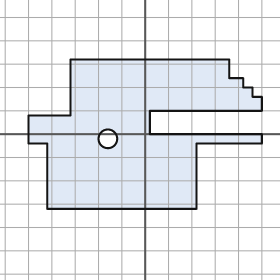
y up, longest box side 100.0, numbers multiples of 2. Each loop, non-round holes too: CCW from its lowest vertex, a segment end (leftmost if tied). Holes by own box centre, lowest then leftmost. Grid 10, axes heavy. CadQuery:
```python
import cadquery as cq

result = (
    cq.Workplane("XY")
    .moveTo(-42.0, -32.0)
    .lineTo(22.0, -32.0)
    .lineTo(22.0, -4.0)
    .lineTo(50.0, -4.0)
    .lineTo(50.0, 0.0)
    .lineTo(2.0, 0.0)
    .lineTo(2.0, 10.0)
    .lineTo(50.0, 10.0)
    .lineTo(50.0, 16.0)
    .lineTo(46.0, 16.0)
    .lineTo(46.0, 20.0)
    .lineTo(42.0, 20.0)
    .lineTo(42.0, 24.0)
    .lineTo(36.0, 24.0)
    .lineTo(36.0, 32.0)
    .lineTo(-32.0, 32.0)
    .lineTo(-32.0, 8.0)
    .lineTo(-50.0, 8.0)
    .lineTo(-50.0, -4.0)
    .lineTo(-42.0, -4.0)
    .close()
    .moveTo(-16.0, -2.0)
    .circle(4.0)
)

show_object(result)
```